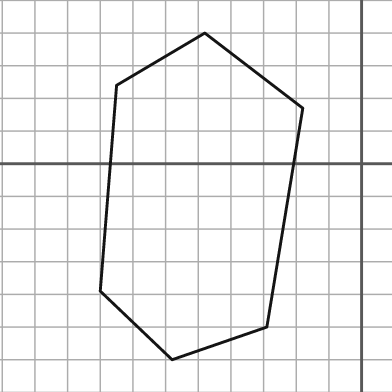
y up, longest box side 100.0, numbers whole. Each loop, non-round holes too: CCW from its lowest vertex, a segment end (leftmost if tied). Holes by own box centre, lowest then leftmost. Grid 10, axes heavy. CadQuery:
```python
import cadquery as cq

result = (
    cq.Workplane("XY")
    .moveTo(-58.0, -60.0)
    .lineTo(-29.0, -50.0)
    .lineTo(-18.0, 17.0)
    .lineTo(-48.0, 40.0)
    .lineTo(-75.0, 24.0)
    .lineTo(-80.0, -39.0)
    .close()
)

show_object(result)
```